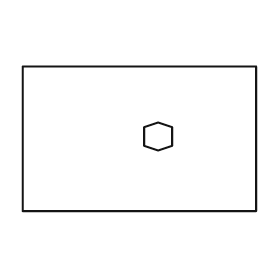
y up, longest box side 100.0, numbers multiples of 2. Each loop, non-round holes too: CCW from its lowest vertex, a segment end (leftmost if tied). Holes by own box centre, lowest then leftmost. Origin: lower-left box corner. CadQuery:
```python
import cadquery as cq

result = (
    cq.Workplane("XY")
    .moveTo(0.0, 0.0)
    .lineTo(100.0, 0.0)
    .lineTo(100.0, 62.0)
    .lineTo(0.0, 62.0)
    .close()
    .moveTo(58.0, 26.0)
    .lineTo(64.0, 28.0)
    .lineTo(64.0, 36.0)
    .lineTo(58.0, 38.0)
    .lineTo(52.0, 36.0)
    .lineTo(52.0, 28.0)
    .close()
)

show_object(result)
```